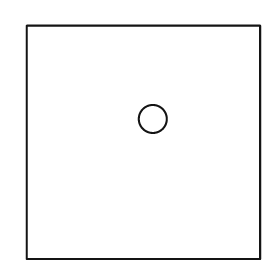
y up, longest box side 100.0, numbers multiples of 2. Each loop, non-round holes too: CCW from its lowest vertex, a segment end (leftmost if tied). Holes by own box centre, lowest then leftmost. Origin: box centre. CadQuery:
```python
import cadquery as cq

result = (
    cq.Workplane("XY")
    .moveTo(-50.0, -50.0)
    .lineTo(50.0, -50.0)
    .lineTo(50.0, 50.0)
    .lineTo(-50.0, 50.0)
    .close()
    .moveTo(4.0, 10.0)
    .circle(6.0)
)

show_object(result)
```